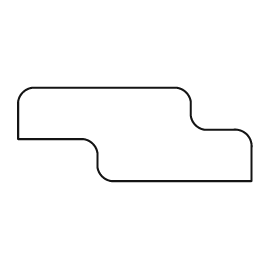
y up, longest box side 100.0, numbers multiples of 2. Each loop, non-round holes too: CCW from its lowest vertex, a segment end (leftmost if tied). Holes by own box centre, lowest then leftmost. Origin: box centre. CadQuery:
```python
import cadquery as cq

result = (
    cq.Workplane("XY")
    .moveTo(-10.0, -20.0)
    .lineTo(50.0, -20.0)
    .lineTo(50.0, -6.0)
    .threePointArc((48.0, 0.0), (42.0, 2.0))
    .lineTo(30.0, 2.0)
    .threePointArc((26.0, 4.0), (24.0, 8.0))
    .lineTo(24.0, 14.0)
    .threePointArc((22.0, 18.0), (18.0, 20.0))
    .lineTo(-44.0, 20.0)
    .threePointArc((-48.0, 18.0), (-50.0, 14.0))
    .lineTo(-50.0, -2.0)
    .lineTo(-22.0, -2.0)
    .threePointArc((-18.0, -4.0), (-16.0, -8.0))
    .lineTo(-16.0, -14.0)
    .threePointArc((-14.0, -18.0), (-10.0, -20.0))
    .close()
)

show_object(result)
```